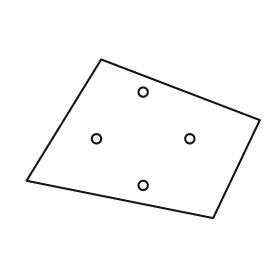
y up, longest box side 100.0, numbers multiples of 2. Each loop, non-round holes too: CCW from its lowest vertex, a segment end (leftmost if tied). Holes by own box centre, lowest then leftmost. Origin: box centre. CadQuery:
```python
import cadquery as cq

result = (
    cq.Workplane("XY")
    .moveTo(30.0, -34.0)
    .lineTo(50.0, 8.0)
    .lineTo(-18.0, 34.0)
    .lineTo(-50.0, -18.0)
    .close()
    .moveTo(0.0, -20.0)
    .circle(2.0)
    .moveTo(-20.0, 0.0)
    .circle(2.0)
    .moveTo(20.0, 0.0)
    .circle(2.0)
    .moveTo(0.0, 20.0)
    .circle(2.0)
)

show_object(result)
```